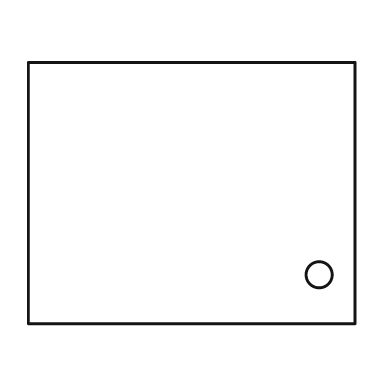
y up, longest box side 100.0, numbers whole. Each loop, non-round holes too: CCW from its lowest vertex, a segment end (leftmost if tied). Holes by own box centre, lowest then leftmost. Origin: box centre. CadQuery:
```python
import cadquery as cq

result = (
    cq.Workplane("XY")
    .moveTo(-50.0, -40.0)
    .lineTo(50.0, -40.0)
    .lineTo(50.0, 40.0)
    .lineTo(-50.0, 40.0)
    .close()
    .moveTo(39.0, -25.0)
    .circle(4.0)
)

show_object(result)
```